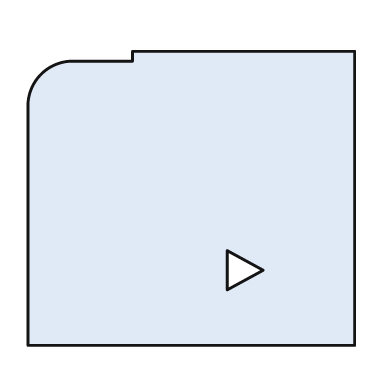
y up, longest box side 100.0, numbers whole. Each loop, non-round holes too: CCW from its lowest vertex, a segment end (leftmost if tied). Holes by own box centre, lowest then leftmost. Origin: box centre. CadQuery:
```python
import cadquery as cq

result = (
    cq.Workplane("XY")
    .moveTo(-50.0, -45.0)
    .lineTo(50.0, -45.0)
    .lineTo(50.0, 45.0)
    .lineTo(-18.0, 45.0)
    .lineTo(-18.0, 42.0)
    .lineTo(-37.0, 42.0)
    .threePointArc((-46.0, 38.0), (-50.0, 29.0))
    .close()
    .moveTo(11.0, -28.0)
    .lineTo(22.0, -22.0)
    .lineTo(11.0, -16.0)
    .close()
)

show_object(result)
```